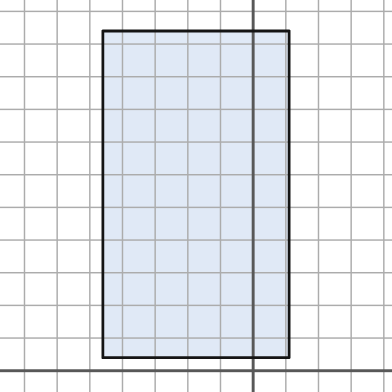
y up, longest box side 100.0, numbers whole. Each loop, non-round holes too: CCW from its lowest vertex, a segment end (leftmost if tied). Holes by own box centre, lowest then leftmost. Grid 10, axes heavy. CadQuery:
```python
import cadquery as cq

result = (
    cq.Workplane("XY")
    .moveTo(-46.0, 4.0)
    .lineTo(11.0, 4.0)
    .lineTo(11.0, 104.0)
    .lineTo(-46.0, 104.0)
    .close()
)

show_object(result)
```